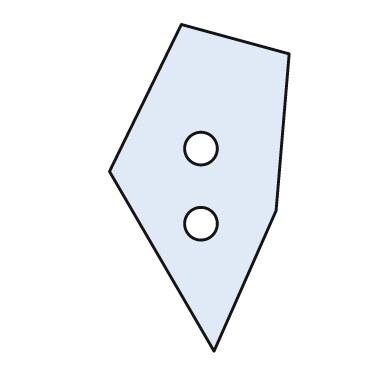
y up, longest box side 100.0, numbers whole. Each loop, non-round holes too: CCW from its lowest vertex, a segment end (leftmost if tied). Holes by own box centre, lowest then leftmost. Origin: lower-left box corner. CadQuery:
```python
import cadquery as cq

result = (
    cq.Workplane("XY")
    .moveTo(32.0, 0.0)
    .lineTo(51.0, 43.0)
    .lineTo(55.0, 91.0)
    .lineTo(22.0, 100.0)
    .lineTo(0.0, 55.0)
    .close()
    .moveTo(28.0, 39.0)
    .circle(5.0)
    .moveTo(28.0, 62.0)
    .circle(5.0)
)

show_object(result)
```